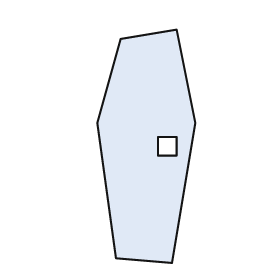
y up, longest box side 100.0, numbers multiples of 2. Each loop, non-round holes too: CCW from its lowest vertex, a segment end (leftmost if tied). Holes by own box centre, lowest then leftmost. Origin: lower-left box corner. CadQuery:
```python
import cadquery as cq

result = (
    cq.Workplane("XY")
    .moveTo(32.0, 0.0)
    .lineTo(42.0, 60.0)
    .lineTo(34.0, 100.0)
    .lineTo(10.0, 96.0)
    .lineTo(0.0, 60.0)
    .lineTo(8.0, 2.0)
    .close()
    .moveTo(26.0, 46.0)
    .lineTo(34.0, 46.0)
    .lineTo(34.0, 54.0)
    .lineTo(26.0, 54.0)
    .close()
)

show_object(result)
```